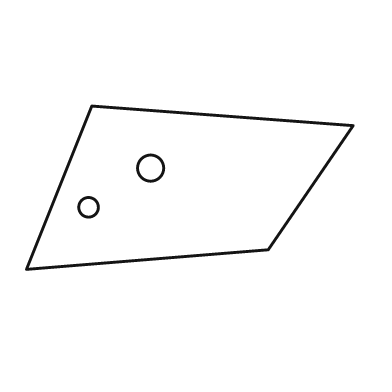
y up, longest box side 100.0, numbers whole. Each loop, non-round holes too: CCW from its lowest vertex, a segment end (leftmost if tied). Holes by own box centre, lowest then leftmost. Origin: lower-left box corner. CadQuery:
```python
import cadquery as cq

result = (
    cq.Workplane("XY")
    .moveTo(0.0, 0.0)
    .lineTo(74.0, 6.0)
    .lineTo(100.0, 44.0)
    .lineTo(20.0, 50.0)
    .close()
    .moveTo(19.0, 19.0)
    .circle(3.0)
    .moveTo(38.0, 31.0)
    .circle(4.0)
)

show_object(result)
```